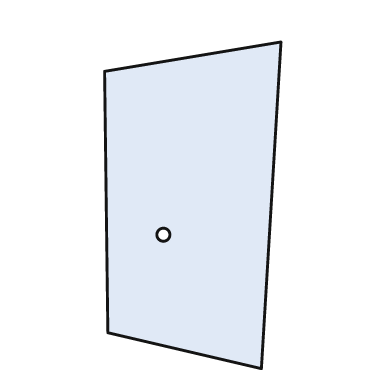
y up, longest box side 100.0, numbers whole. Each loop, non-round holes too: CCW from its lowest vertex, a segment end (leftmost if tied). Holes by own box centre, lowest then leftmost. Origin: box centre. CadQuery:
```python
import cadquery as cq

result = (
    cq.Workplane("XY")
    .moveTo(21.0, -50.0)
    .lineTo(27.0, 50.0)
    .lineTo(-27.0, 41.0)
    .lineTo(-26.0, -39.0)
    .close()
    .moveTo(-9.0, -9.0)
    .circle(2.0)
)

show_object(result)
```